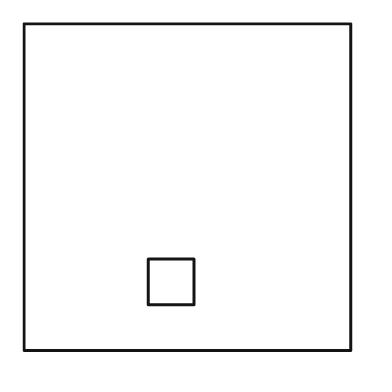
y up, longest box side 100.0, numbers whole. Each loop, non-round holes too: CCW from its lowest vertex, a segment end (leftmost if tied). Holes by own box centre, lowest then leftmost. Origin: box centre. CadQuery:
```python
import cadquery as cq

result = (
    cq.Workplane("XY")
    .moveTo(-50.0, -50.0)
    .lineTo(50.0, -50.0)
    .lineTo(50.0, 50.0)
    .lineTo(-50.0, 50.0)
    .close()
    .moveTo(-12.0, -36.0)
    .lineTo(2.0, -36.0)
    .lineTo(2.0, -22.0)
    .lineTo(-12.0, -22.0)
    .close()
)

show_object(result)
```